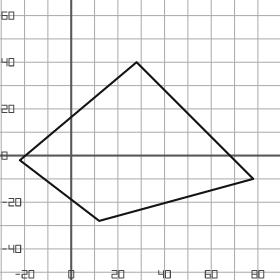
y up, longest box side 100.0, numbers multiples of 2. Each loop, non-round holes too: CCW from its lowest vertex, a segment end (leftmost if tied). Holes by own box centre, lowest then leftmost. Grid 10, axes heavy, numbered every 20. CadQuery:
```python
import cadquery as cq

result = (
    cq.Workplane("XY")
    .moveTo(12.0, -28.0)
    .lineTo(78.0, -10.0)
    .lineTo(28.0, 40.0)
    .lineTo(-22.0, -2.0)
    .close()
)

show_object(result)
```